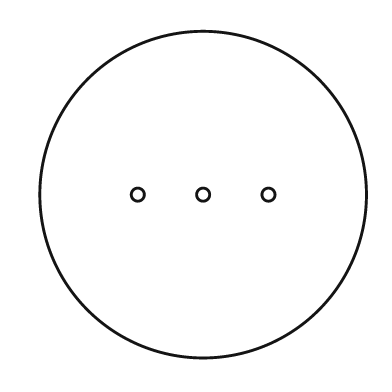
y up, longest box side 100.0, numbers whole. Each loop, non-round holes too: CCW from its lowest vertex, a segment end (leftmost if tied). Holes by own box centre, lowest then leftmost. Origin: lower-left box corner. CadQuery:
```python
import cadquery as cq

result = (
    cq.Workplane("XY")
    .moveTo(50.0, 50.0)
    .circle(50.0)
    .moveTo(30.0, 50.0)
    .circle(2.0)
    .moveTo(50.0, 50.0)
    .circle(2.0)
    .moveTo(70.0, 50.0)
    .circle(2.0)
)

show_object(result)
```